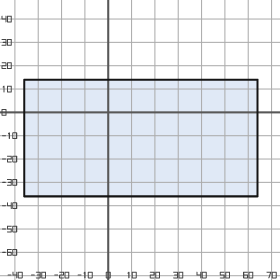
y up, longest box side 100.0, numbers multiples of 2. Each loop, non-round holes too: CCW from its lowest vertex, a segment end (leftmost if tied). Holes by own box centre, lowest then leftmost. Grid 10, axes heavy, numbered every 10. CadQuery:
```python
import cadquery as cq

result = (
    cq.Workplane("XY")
    .moveTo(-36.0, -36.0)
    .lineTo(64.0, -36.0)
    .lineTo(64.0, 14.0)
    .lineTo(-36.0, 14.0)
    .close()
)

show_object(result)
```